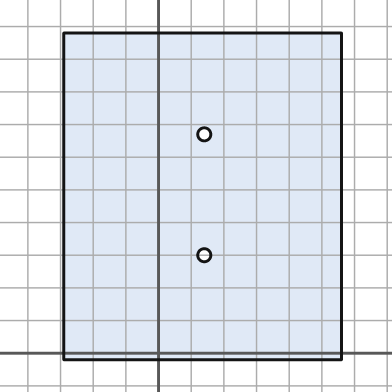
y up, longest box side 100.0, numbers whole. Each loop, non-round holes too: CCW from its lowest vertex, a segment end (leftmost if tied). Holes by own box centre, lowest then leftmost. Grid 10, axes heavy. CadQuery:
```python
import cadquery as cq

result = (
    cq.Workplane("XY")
    .moveTo(-29.0, -2.0)
    .lineTo(56.0, -2.0)
    .lineTo(56.0, 98.0)
    .lineTo(-29.0, 98.0)
    .close()
    .moveTo(14.0, 30.0)
    .circle(2.0)
    .moveTo(14.0, 67.0)
    .circle(2.0)
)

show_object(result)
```